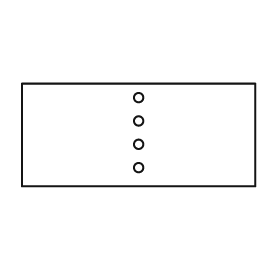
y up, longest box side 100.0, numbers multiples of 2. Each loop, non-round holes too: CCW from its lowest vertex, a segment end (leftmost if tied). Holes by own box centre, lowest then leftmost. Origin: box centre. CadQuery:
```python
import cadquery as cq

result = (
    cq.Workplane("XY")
    .moveTo(-50.0, -22.0)
    .lineTo(50.0, -22.0)
    .lineTo(50.0, 22.0)
    .lineTo(-50.0, 22.0)
    .close()
    .moveTo(0.0, -14.0)
    .circle(2.0)
    .moveTo(0.0, -4.0)
    .circle(2.0)
    .moveTo(0.0, 6.0)
    .circle(2.0)
    .moveTo(0.0, 16.0)
    .circle(2.0)
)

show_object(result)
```